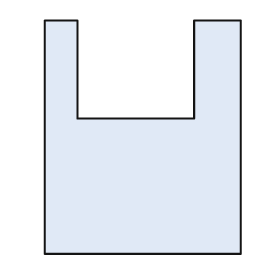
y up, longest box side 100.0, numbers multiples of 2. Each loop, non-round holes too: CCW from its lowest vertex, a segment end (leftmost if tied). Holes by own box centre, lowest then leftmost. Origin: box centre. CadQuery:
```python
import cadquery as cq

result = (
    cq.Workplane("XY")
    .moveTo(-42.0, -50.0)
    .lineTo(42.0, -50.0)
    .lineTo(42.0, 50.0)
    .lineTo(22.0, 50.0)
    .lineTo(22.0, 8.0)
    .lineTo(-28.0, 8.0)
    .lineTo(-28.0, 50.0)
    .lineTo(-42.0, 50.0)
    .close()
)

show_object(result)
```